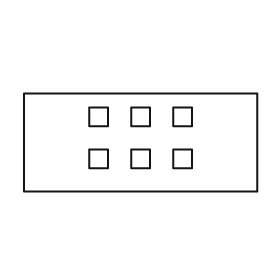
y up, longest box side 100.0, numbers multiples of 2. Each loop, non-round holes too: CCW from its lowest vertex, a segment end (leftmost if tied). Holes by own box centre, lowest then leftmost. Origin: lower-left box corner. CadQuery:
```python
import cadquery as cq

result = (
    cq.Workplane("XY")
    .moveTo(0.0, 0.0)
    .lineTo(100.0, 0.0)
    .lineTo(100.0, 42.0)
    .lineTo(0.0, 42.0)
    .close()
    .moveTo(28.0, 10.0)
    .lineTo(36.0, 10.0)
    .lineTo(36.0, 18.0)
    .lineTo(28.0, 18.0)
    .close()
    .moveTo(46.0, 10.0)
    .lineTo(54.0, 10.0)
    .lineTo(54.0, 18.0)
    .lineTo(46.0, 18.0)
    .close()
    .moveTo(64.0, 10.0)
    .lineTo(72.0, 10.0)
    .lineTo(72.0, 18.0)
    .lineTo(64.0, 18.0)
    .close()
    .moveTo(28.0, 28.0)
    .lineTo(36.0, 28.0)
    .lineTo(36.0, 36.0)
    .lineTo(28.0, 36.0)
    .close()
    .moveTo(46.0, 28.0)
    .lineTo(54.0, 28.0)
    .lineTo(54.0, 36.0)
    .lineTo(46.0, 36.0)
    .close()
    .moveTo(64.0, 28.0)
    .lineTo(72.0, 28.0)
    .lineTo(72.0, 36.0)
    .lineTo(64.0, 36.0)
    .close()
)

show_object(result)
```